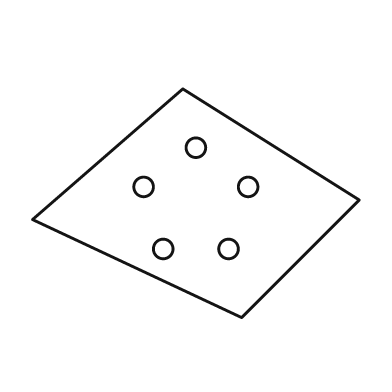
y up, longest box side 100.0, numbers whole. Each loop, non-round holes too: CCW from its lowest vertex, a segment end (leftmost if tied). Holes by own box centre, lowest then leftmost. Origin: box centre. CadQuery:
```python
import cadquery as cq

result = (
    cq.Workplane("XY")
    .moveTo(14.0, -35.0)
    .lineTo(50.0, 1.0)
    .lineTo(-4.0, 35.0)
    .lineTo(-50.0, -5.0)
    .close()
    .moveTo(-10.0, -14.0)
    .circle(3.0)
    .moveTo(10.0, -14.0)
    .circle(3.0)
    .moveTo(-16.0, 5.0)
    .circle(3.0)
    .moveTo(16.0, 5.0)
    .circle(3.0)
    .moveTo(0.0, 17.0)
    .circle(3.0)
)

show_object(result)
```